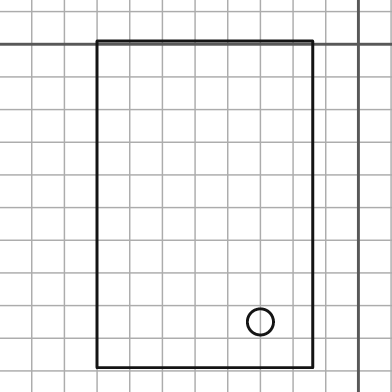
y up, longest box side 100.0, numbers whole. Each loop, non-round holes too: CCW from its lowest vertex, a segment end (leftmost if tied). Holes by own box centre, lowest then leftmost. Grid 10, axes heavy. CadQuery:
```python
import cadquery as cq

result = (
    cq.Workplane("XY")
    .moveTo(-80.0, -99.0)
    .lineTo(-14.0, -99.0)
    .lineTo(-14.0, 1.0)
    .lineTo(-80.0, 1.0)
    .close()
    .moveTo(-30.0, -85.0)
    .circle(4.0)
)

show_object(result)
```